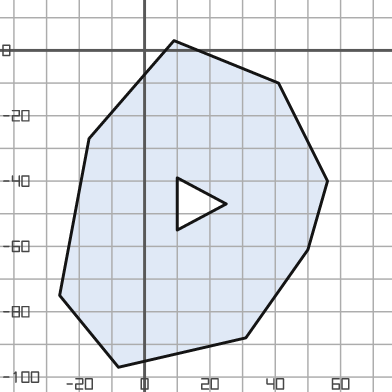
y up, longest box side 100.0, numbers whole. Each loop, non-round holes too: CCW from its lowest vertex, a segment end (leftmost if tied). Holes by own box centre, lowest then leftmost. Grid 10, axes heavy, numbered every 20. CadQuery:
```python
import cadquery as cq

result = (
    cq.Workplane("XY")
    .moveTo(-8.0, -97.0)
    .lineTo(31.0, -88.0)
    .lineTo(50.0, -61.0)
    .lineTo(56.0, -40.0)
    .lineTo(41.0, -10.0)
    .lineTo(9.0, 3.0)
    .lineTo(-17.0, -27.0)
    .lineTo(-26.0, -75.0)
    .close()
    .moveTo(10.0, -55.0)
    .lineTo(25.0, -47.0)
    .lineTo(10.0, -39.0)
    .close()
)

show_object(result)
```